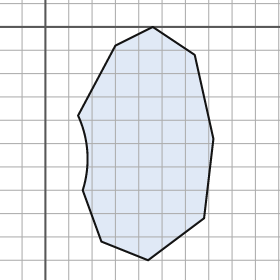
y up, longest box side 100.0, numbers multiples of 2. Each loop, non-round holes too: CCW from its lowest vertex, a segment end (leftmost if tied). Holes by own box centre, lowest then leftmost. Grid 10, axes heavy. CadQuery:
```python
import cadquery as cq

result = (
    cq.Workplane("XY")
    .moveTo(44.0, -100.0)
    .lineTo(68.0, -82.0)
    .lineTo(72.0, -48.0)
    .lineTo(64.0, -12.0)
    .lineTo(46.0, 0.0)
    .lineTo(30.0, -8.0)
    .lineTo(14.0, -38.0)
    .threePointArc((18.0, -54.0), (16.0, -70.0))
    .lineTo(24.0, -92.0)
    .close()
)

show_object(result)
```